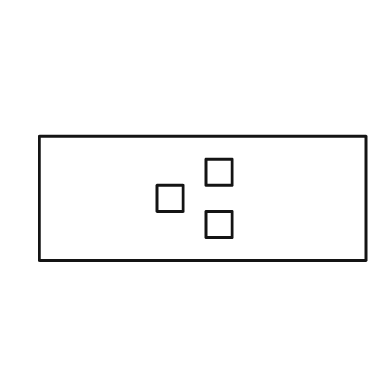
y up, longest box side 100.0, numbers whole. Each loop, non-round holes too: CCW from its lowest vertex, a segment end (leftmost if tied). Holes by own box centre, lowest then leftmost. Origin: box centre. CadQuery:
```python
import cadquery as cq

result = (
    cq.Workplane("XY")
    .moveTo(-50.0, -19.0)
    .lineTo(50.0, -19.0)
    .lineTo(50.0, 19.0)
    .lineTo(-50.0, 19.0)
    .close()
    .moveTo(1.0, -12.0)
    .lineTo(9.0, -12.0)
    .lineTo(9.0, -4.0)
    .lineTo(1.0, -4.0)
    .close()
    .moveTo(-14.0, -4.0)
    .lineTo(-6.0, -4.0)
    .lineTo(-6.0, 4.0)
    .lineTo(-14.0, 4.0)
    .close()
    .moveTo(1.0, 4.0)
    .lineTo(9.0, 4.0)
    .lineTo(9.0, 12.0)
    .lineTo(1.0, 12.0)
    .close()
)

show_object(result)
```